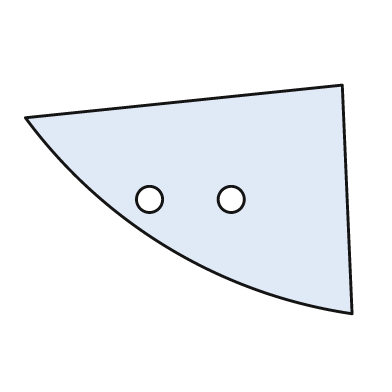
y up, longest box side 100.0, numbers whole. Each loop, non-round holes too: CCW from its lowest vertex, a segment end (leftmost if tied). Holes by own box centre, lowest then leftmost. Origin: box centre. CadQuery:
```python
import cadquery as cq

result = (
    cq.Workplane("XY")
    .moveTo(50.0, -35.0)
    .lineTo(47.0, 35.0)
    .lineTo(-50.0, 25.0)
    .threePointArc((-6.0, -15.0), (50.0, -35.0))
    .close()
    .moveTo(-12.0, 0.0)
    .circle(4.0)
    .moveTo(13.0, 0.0)
    .circle(4.0)
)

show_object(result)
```